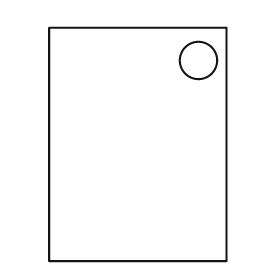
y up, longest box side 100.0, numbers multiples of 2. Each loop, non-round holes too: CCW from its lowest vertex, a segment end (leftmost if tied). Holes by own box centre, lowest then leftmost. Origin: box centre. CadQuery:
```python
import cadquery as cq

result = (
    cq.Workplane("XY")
    .moveTo(-38.0, -50.0)
    .lineTo(38.0, -50.0)
    .lineTo(38.0, 50.0)
    .lineTo(-38.0, 50.0)
    .close()
    .moveTo(26.0, 36.0)
    .circle(8.0)
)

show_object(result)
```